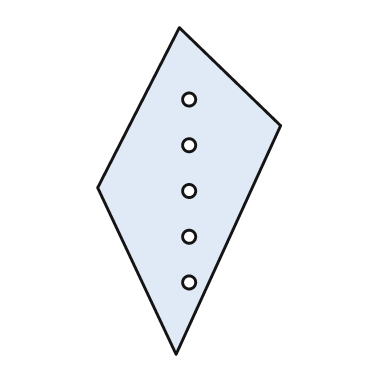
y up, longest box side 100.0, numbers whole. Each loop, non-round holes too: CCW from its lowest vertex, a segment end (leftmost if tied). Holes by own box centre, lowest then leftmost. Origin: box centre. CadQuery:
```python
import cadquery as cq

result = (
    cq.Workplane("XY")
    .moveTo(-4.0, -50.0)
    .lineTo(28.0, 20.0)
    .lineTo(-3.0, 50.0)
    .lineTo(-28.0, 1.0)
    .close()
    .moveTo(0.0, -28.0)
    .circle(2.0)
    .moveTo(0.0, -14.0)
    .circle(2.0)
    .moveTo(0.0, 0.0)
    .circle(2.0)
    .moveTo(0.0, 14.0)
    .circle(2.0)
    .moveTo(0.0, 28.0)
    .circle(2.0)
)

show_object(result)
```